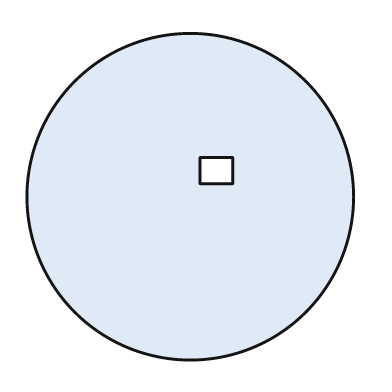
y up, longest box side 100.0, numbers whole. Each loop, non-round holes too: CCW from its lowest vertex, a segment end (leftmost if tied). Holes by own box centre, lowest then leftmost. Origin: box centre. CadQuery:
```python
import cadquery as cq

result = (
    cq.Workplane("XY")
    .moveTo(0.0, 0.0)
    .circle(50.0)
    .moveTo(3.0, 4.0)
    .lineTo(13.0, 4.0)
    .lineTo(13.0, 12.0)
    .lineTo(3.0, 12.0)
    .close()
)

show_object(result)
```